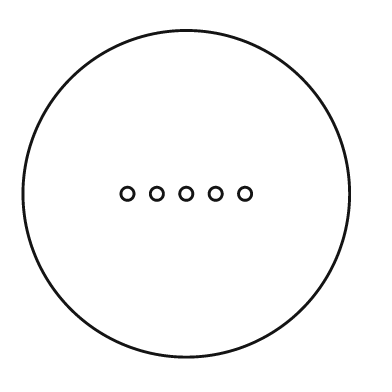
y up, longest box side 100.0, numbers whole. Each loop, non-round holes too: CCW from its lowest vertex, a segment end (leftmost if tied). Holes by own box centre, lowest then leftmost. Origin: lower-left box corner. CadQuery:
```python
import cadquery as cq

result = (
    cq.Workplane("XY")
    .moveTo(50.0, 50.0)
    .circle(50.0)
    .moveTo(32.0, 50.0)
    .circle(2.0)
    .moveTo(41.0, 50.0)
    .circle(2.0)
    .moveTo(50.0, 50.0)
    .circle(2.0)
    .moveTo(59.0, 50.0)
    .circle(2.0)
    .moveTo(68.0, 50.0)
    .circle(2.0)
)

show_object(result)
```